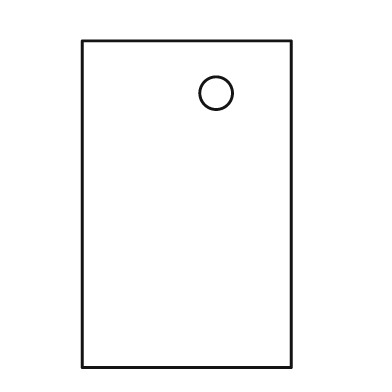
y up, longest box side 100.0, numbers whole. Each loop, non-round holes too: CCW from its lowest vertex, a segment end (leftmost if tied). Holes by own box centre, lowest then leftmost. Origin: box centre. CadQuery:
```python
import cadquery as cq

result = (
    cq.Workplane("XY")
    .moveTo(-32.0, -50.0)
    .lineTo(32.0, -50.0)
    .lineTo(32.0, 50.0)
    .lineTo(-32.0, 50.0)
    .close()
    .moveTo(9.0, 34.0)
    .circle(5.0)
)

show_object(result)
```